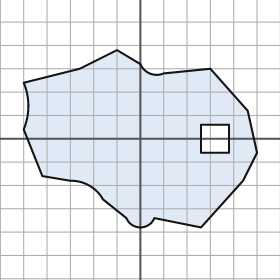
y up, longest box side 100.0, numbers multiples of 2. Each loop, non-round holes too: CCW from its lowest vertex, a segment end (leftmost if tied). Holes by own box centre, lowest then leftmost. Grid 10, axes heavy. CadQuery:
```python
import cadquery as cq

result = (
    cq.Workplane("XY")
    .moveTo(26.0, -38.0)
    .lineTo(44.0, -18.0)
    .lineTo(50.0, -6.0)
    .lineTo(46.0, 12.0)
    .lineTo(30.0, 30.0)
    .lineTo(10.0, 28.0)
    .threePointArc((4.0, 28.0), (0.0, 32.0))
    .lineTo(-10.0, 38.0)
    .lineTo(-26.0, 30.0)
    .lineTo(-50.0, 24.0)
    .threePointArc((-48.0, 14.0), (-50.0, 4.0))
    .lineTo(-42.0, -16.0)
    .lineTo(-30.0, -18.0)
    .threePointArc((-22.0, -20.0), (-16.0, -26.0))
    .lineTo(-6.0, -34.0)
    .threePointArc((0.0, -38.0), (6.0, -34.0))
    .close()
    .moveTo(26.0, -6.0)
    .lineTo(38.0, -6.0)
    .lineTo(38.0, 6.0)
    .lineTo(26.0, 6.0)
    .close()
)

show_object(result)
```